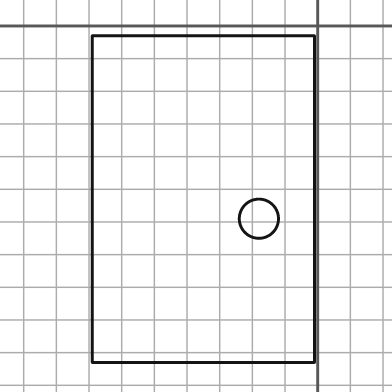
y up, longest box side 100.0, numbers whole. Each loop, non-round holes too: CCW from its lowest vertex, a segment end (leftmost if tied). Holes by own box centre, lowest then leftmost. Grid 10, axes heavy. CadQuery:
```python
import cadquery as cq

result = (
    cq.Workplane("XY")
    .moveTo(-69.0, -103.0)
    .lineTo(-1.0, -103.0)
    .lineTo(-1.0, -3.0)
    .lineTo(-69.0, -3.0)
    .close()
    .moveTo(-18.0, -59.0)
    .circle(6.0)
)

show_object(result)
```